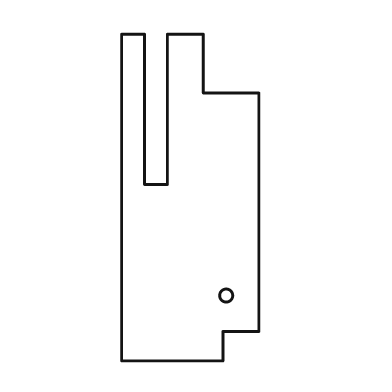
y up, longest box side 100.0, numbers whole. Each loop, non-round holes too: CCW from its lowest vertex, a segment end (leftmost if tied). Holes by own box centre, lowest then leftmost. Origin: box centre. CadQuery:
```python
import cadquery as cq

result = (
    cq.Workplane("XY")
    .moveTo(-21.0, -50.0)
    .lineTo(10.0, -50.0)
    .lineTo(10.0, -41.0)
    .lineTo(21.0, -41.0)
    .lineTo(21.0, 32.0)
    .lineTo(4.0, 32.0)
    .lineTo(4.0, 50.0)
    .lineTo(-7.0, 50.0)
    .lineTo(-7.0, 4.0)
    .lineTo(-14.0, 4.0)
    .lineTo(-14.0, 50.0)
    .lineTo(-21.0, 50.0)
    .close()
    .moveTo(11.0, -30.0)
    .circle(2.0)
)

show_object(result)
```